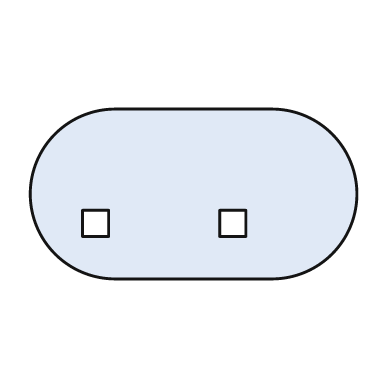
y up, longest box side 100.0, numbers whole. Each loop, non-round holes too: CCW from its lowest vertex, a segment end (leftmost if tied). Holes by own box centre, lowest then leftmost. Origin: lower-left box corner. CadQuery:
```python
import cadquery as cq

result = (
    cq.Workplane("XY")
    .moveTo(26.0, 0.0)
    .lineTo(74.0, 0.0)
    .threePointArc((100.0, 26.0), (74.0, 52.0))
    .lineTo(26.0, 52.0)
    .threePointArc((0.0, 26.0), (26.0, 0.0))
    .close()
    .moveTo(16.0, 13.0)
    .lineTo(24.0, 13.0)
    .lineTo(24.0, 21.0)
    .lineTo(16.0, 21.0)
    .close()
    .moveTo(58.0, 13.0)
    .lineTo(66.0, 13.0)
    .lineTo(66.0, 21.0)
    .lineTo(58.0, 21.0)
    .close()
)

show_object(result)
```